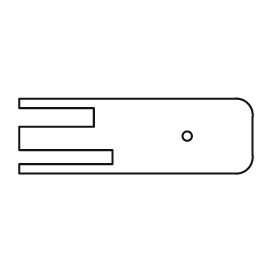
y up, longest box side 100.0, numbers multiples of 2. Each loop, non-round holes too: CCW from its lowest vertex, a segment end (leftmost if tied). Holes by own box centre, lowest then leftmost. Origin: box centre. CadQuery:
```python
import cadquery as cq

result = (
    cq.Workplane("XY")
    .moveTo(-50.0, -16.0)
    .lineTo(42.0, -16.0)
    .threePointArc((48.0, -14.0), (50.0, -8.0))
    .lineTo(50.0, 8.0)
    .threePointArc((48.0, 14.0), (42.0, 16.0))
    .lineTo(-50.0, 16.0)
    .lineTo(-50.0, 12.0)
    .lineTo(-18.0, 12.0)
    .lineTo(-18.0, 4.0)
    .lineTo(-50.0, 4.0)
    .lineTo(-50.0, -6.0)
    .lineTo(-10.0, -6.0)
    .lineTo(-10.0, -12.0)
    .lineTo(-50.0, -12.0)
    .close()
    .moveTo(22.0, 0.0)
    .circle(2.0)
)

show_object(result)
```